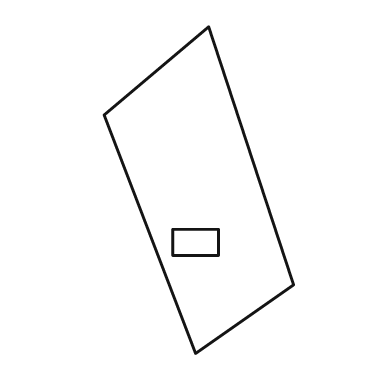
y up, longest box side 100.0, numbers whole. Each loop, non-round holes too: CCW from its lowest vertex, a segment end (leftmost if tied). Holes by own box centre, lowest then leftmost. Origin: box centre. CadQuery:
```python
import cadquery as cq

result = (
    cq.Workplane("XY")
    .moveTo(-1.0, -50.0)
    .lineTo(29.0, -29.0)
    .lineTo(3.0, 50.0)
    .lineTo(-29.0, 23.0)
    .close()
    .moveTo(-8.0, -20.0)
    .lineTo(6.0, -20.0)
    .lineTo(6.0, -12.0)
    .lineTo(-8.0, -12.0)
    .close()
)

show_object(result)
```